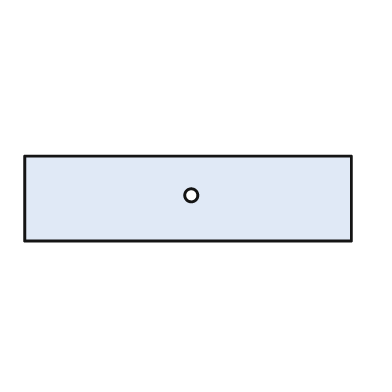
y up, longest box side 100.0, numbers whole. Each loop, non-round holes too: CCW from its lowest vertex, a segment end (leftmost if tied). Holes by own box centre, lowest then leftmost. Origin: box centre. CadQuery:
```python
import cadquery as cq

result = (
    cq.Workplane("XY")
    .moveTo(-50.0, -13.0)
    .lineTo(50.0, -13.0)
    .lineTo(50.0, 13.0)
    .lineTo(-50.0, 13.0)
    .close()
    .moveTo(1.0, 1.0)
    .circle(2.0)
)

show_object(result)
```